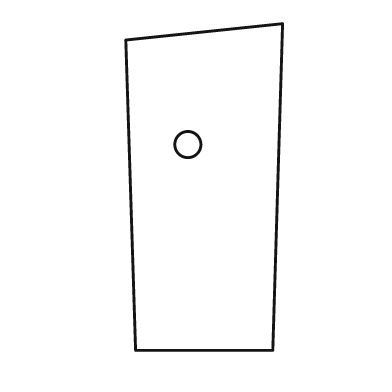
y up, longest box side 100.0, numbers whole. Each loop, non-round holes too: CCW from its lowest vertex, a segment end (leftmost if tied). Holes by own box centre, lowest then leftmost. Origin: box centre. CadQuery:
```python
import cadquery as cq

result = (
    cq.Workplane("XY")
    .moveTo(-21.0, -50.0)
    .lineTo(21.0, -50.0)
    .lineTo(24.0, 50.0)
    .lineTo(-24.0, 45.0)
    .close()
    .moveTo(-5.0, 13.0)
    .circle(4.0)
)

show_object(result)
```